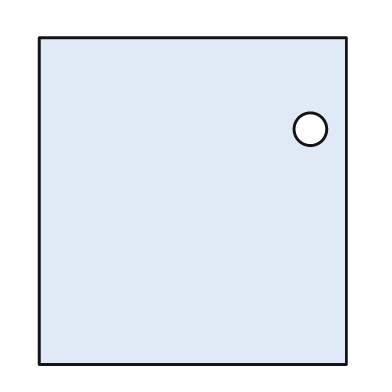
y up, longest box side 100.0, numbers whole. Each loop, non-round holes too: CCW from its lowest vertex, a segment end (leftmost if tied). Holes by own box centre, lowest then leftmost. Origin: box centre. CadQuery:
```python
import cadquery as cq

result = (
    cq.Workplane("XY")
    .moveTo(-47.0, -50.0)
    .lineTo(47.0, -50.0)
    .lineTo(47.0, 50.0)
    .lineTo(-47.0, 50.0)
    .close()
    .moveTo(36.0, 22.0)
    .circle(5.0)
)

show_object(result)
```